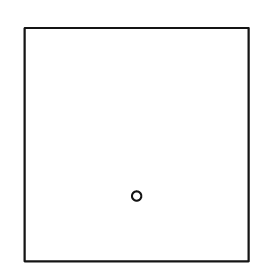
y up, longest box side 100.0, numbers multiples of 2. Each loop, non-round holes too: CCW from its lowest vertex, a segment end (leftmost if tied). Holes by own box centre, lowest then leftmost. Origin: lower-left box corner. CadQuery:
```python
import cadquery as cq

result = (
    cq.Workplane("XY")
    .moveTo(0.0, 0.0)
    .lineTo(96.0, 0.0)
    .lineTo(96.0, 100.0)
    .lineTo(0.0, 100.0)
    .close()
    .moveTo(48.0, 28.0)
    .circle(2.0)
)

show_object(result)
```